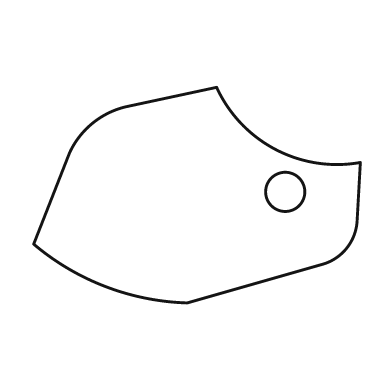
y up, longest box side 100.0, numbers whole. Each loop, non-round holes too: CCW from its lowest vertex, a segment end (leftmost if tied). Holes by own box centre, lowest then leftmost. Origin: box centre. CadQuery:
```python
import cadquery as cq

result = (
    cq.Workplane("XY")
    .moveTo(-3.0, -33.0)
    .lineTo(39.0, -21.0)
    .threePointArc((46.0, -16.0), (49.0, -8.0))
    .lineTo(50.0, 10.0)
    .threePointArc((24.0, 14.0), (6.0, 33.0))
    .lineTo(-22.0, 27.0)
    .threePointArc((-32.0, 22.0), (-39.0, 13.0))
    .lineTo(-50.0, -15.0)
    .threePointArc((-28.0, -28.0), (-3.0, -33.0))
    .close()
    .moveTo(27.0, 1.0)
    .circle(6.0)
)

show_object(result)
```